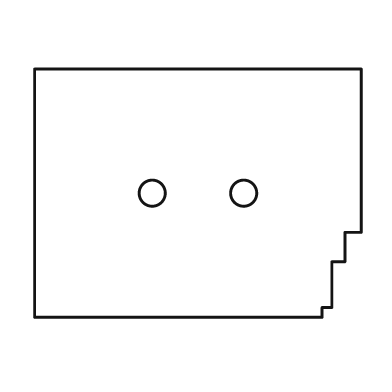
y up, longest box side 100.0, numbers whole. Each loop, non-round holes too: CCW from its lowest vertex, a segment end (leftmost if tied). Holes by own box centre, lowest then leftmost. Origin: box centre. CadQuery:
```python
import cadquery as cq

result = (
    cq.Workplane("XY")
    .moveTo(-50.0, -38.0)
    .lineTo(38.0, -38.0)
    .lineTo(38.0, -35.0)
    .lineTo(41.0, -35.0)
    .lineTo(41.0, -21.0)
    .lineTo(45.0, -21.0)
    .lineTo(45.0, -12.0)
    .lineTo(50.0, -12.0)
    .lineTo(50.0, 38.0)
    .lineTo(-50.0, 38.0)
    .close()
    .moveTo(-14.0, 0.0)
    .circle(4.0)
    .moveTo(14.0, 0.0)
    .circle(4.0)
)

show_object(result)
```